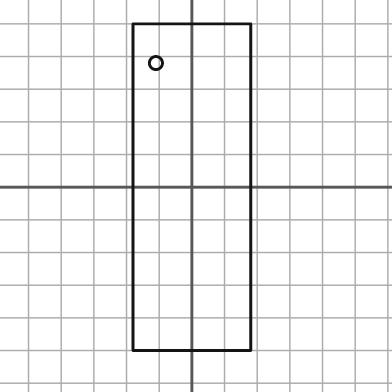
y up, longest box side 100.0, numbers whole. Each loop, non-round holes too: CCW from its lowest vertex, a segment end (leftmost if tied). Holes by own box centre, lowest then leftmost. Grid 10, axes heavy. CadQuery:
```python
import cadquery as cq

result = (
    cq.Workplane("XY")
    .moveTo(-18.0, -50.0)
    .lineTo(18.0, -50.0)
    .lineTo(18.0, 50.0)
    .lineTo(-18.0, 50.0)
    .close()
    .moveTo(-11.0, 38.0)
    .circle(2.0)
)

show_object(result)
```